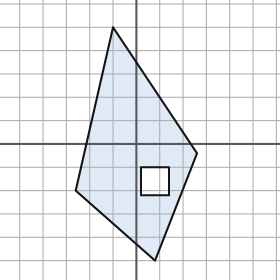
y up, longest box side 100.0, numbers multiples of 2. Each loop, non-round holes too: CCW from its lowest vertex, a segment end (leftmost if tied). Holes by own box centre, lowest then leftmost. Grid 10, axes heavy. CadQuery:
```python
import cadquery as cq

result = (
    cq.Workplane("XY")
    .moveTo(8.0, -50.0)
    .lineTo(26.0, -4.0)
    .lineTo(-10.0, 50.0)
    .lineTo(-26.0, -20.0)
    .close()
    .moveTo(2.0, -22.0)
    .lineTo(14.0, -22.0)
    .lineTo(14.0, -10.0)
    .lineTo(2.0, -10.0)
    .close()
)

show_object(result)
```